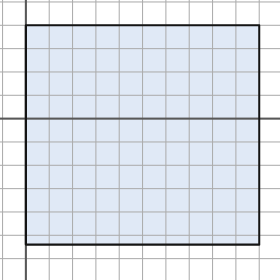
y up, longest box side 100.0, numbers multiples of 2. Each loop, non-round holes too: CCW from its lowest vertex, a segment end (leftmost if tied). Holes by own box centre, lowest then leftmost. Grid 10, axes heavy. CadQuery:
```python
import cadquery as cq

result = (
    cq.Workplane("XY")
    .moveTo(0.0, -54.0)
    .lineTo(100.0, -54.0)
    .lineTo(100.0, 40.0)
    .lineTo(0.0, 40.0)
    .close()
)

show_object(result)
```